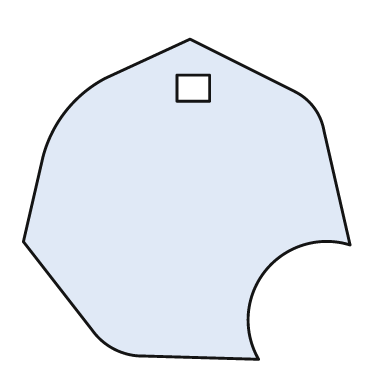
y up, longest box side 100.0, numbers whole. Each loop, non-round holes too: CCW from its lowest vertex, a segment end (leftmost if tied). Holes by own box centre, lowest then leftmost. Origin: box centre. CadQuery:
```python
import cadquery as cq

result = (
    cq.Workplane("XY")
    .moveTo(22.0, -49.0)
    .threePointArc((24.0, -22.0), (50.0, -14.0))
    .lineTo(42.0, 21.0)
    .threePointArc((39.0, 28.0), (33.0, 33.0))
    .lineTo(1.0, 49.0)
    .lineTo(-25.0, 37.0)
    .threePointArc((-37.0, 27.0), (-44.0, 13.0))
    .lineTo(-50.0, -13.0)
    .lineTo(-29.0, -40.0)
    .threePointArc((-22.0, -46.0), (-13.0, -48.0))
    .close()
    .moveTo(-3.0, 30.0)
    .lineTo(7.0, 30.0)
    .lineTo(7.0, 38.0)
    .lineTo(-3.0, 38.0)
    .close()
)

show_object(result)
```